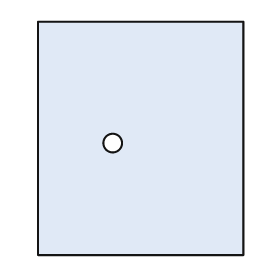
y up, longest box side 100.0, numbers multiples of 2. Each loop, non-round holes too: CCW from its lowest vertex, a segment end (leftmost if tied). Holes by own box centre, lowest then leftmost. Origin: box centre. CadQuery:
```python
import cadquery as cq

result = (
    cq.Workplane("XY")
    .moveTo(-44.0, -50.0)
    .lineTo(44.0, -50.0)
    .lineTo(44.0, 50.0)
    .lineTo(-44.0, 50.0)
    .close()
    .moveTo(-12.0, -2.0)
    .circle(4.0)
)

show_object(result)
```